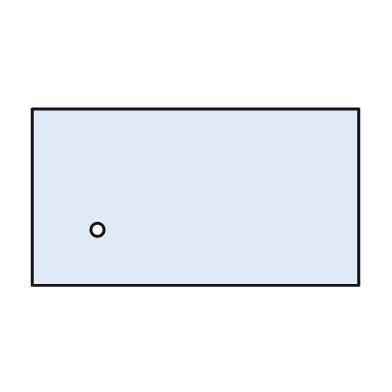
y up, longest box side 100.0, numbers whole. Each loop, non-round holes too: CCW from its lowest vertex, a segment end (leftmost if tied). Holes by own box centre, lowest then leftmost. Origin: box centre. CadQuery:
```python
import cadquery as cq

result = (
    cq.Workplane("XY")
    .moveTo(-50.0, -27.0)
    .lineTo(50.0, -27.0)
    .lineTo(50.0, 27.0)
    .lineTo(-50.0, 27.0)
    .close()
    .moveTo(-30.0, -10.0)
    .circle(2.0)
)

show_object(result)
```